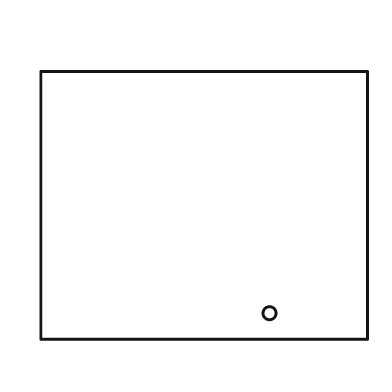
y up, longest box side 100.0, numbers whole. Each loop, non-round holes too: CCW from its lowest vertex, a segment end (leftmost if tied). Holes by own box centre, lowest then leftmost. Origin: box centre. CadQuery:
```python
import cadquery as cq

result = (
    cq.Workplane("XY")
    .moveTo(-50.0, -41.0)
    .lineTo(50.0, -41.0)
    .lineTo(50.0, 41.0)
    .lineTo(-50.0, 41.0)
    .close()
    .moveTo(20.0, -33.0)
    .circle(2.0)
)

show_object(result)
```